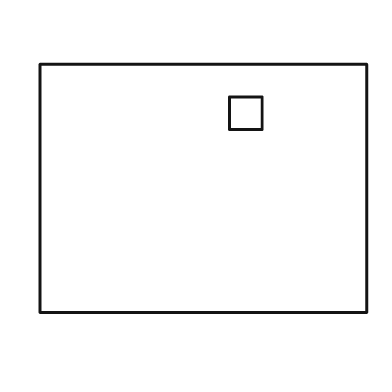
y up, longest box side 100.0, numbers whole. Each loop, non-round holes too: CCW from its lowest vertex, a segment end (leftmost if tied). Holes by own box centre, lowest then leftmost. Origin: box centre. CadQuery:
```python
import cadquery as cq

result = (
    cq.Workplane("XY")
    .moveTo(-50.0, -38.0)
    .lineTo(50.0, -38.0)
    .lineTo(50.0, 38.0)
    .lineTo(-50.0, 38.0)
    .close()
    .moveTo(8.0, 18.0)
    .lineTo(18.0, 18.0)
    .lineTo(18.0, 28.0)
    .lineTo(8.0, 28.0)
    .close()
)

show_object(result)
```